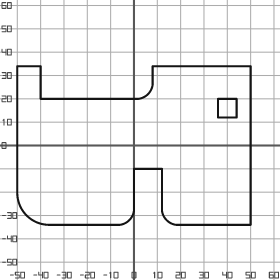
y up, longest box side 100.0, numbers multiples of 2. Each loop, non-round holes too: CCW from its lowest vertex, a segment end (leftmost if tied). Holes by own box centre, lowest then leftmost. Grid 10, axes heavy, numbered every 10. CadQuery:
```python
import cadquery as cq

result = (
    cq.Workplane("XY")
    .moveTo(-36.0, -34.0)
    .lineTo(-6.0, -34.0)
    .threePointArc((-2.0, -32.0), (0.0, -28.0))
    .lineTo(0.0, -10.0)
    .lineTo(12.0, -10.0)
    .lineTo(12.0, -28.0)
    .threePointArc((14.0, -32.0), (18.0, -34.0))
    .lineTo(50.0, -34.0)
    .lineTo(50.0, 34.0)
    .lineTo(8.0, 34.0)
    .lineTo(8.0, 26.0)
    .threePointArc((6.0, 22.0), (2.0, 20.0))
    .lineTo(-40.0, 20.0)
    .lineTo(-40.0, 34.0)
    .lineTo(-50.0, 34.0)
    .lineTo(-50.0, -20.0)
    .threePointArc((-46.0, -30.0), (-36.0, -34.0))
    .close()
    .moveTo(36.0, 12.0)
    .lineTo(44.0, 12.0)
    .lineTo(44.0, 20.0)
    .lineTo(36.0, 20.0)
    .close()
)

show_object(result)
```